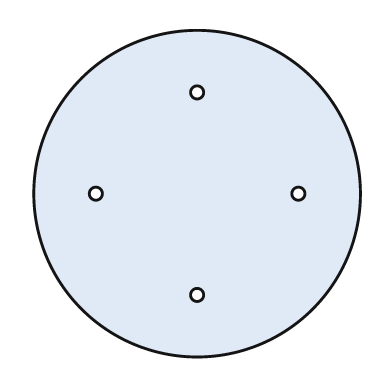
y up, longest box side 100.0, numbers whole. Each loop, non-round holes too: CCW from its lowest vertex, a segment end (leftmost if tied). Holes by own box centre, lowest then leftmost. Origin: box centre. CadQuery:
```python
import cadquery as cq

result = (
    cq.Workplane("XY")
    .moveTo(0.0, 0.0)
    .circle(50.0)
    .moveTo(0.0, -31.0)
    .circle(2.0)
    .moveTo(-31.0, 0.0)
    .circle(2.0)
    .moveTo(31.0, 0.0)
    .circle(2.0)
    .moveTo(0.0, 31.0)
    .circle(2.0)
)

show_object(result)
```